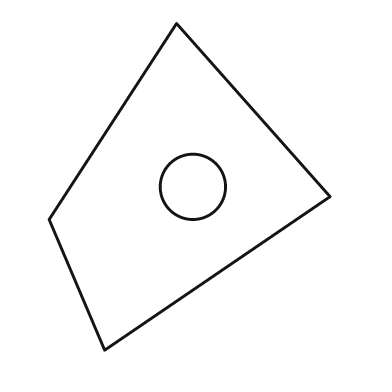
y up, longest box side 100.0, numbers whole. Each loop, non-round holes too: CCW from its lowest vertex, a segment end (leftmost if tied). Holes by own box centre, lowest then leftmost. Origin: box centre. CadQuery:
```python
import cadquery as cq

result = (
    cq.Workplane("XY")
    .moveTo(-26.0, -50.0)
    .lineTo(43.0, -3.0)
    .lineTo(-4.0, 50.0)
    .lineTo(-43.0, -10.0)
    .close()
    .moveTo(1.0, 0.0)
    .circle(10.0)
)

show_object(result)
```